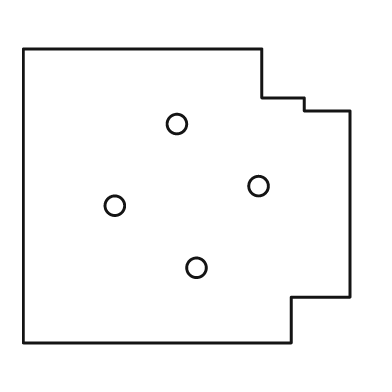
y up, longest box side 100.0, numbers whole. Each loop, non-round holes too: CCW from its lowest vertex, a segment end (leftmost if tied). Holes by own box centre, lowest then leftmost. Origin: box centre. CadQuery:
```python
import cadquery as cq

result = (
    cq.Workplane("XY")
    .moveTo(-50.0, -45.0)
    .lineTo(32.0, -45.0)
    .lineTo(32.0, -31.0)
    .lineTo(50.0, -31.0)
    .lineTo(50.0, 26.0)
    .lineTo(36.0, 26.0)
    .lineTo(36.0, 30.0)
    .lineTo(23.0, 30.0)
    .lineTo(23.0, 45.0)
    .lineTo(-50.0, 45.0)
    .close()
    .moveTo(3.0, -22.0)
    .circle(3.0)
    .moveTo(-22.0, -3.0)
    .circle(3.0)
    .moveTo(22.0, 3.0)
    .circle(3.0)
    .moveTo(-3.0, 22.0)
    .circle(3.0)
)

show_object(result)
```